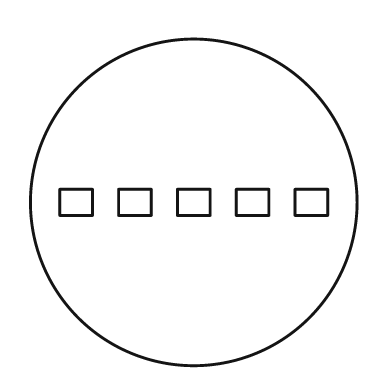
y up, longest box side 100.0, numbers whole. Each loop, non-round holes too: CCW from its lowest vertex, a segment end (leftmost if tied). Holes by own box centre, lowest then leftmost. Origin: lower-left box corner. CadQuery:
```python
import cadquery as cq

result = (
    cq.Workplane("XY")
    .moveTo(50.0, 50.0)
    .circle(50.0)
    .moveTo(9.0, 46.0)
    .lineTo(19.0, 46.0)
    .lineTo(19.0, 54.0)
    .lineTo(9.0, 54.0)
    .close()
    .moveTo(27.0, 46.0)
    .lineTo(37.0, 46.0)
    .lineTo(37.0, 54.0)
    .lineTo(27.0, 54.0)
    .close()
    .moveTo(45.0, 46.0)
    .lineTo(55.0, 46.0)
    .lineTo(55.0, 54.0)
    .lineTo(45.0, 54.0)
    .close()
    .moveTo(63.0, 46.0)
    .lineTo(73.0, 46.0)
    .lineTo(73.0, 54.0)
    .lineTo(63.0, 54.0)
    .close()
    .moveTo(81.0, 46.0)
    .lineTo(91.0, 46.0)
    .lineTo(91.0, 54.0)
    .lineTo(81.0, 54.0)
    .close()
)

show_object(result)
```